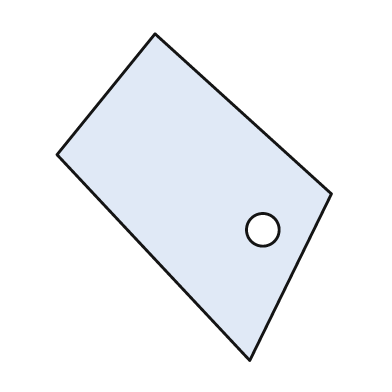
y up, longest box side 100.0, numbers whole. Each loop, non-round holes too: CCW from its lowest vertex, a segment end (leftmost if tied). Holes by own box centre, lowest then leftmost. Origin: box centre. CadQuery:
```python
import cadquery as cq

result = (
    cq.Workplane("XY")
    .moveTo(17.0, -50.0)
    .lineTo(42.0, 1.0)
    .lineTo(-12.0, 50.0)
    .lineTo(-42.0, 13.0)
    .close()
    .moveTo(21.0, -10.0)
    .circle(5.0)
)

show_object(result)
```